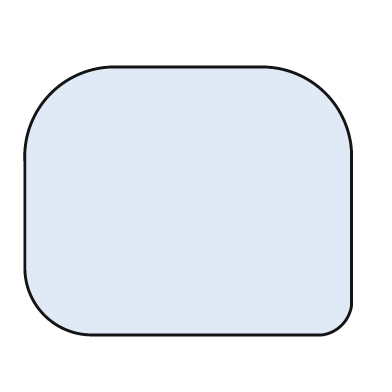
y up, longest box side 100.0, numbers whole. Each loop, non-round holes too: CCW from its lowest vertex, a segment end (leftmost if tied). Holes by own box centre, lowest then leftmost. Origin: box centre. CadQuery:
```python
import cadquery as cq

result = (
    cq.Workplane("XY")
    .moveTo(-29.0, -41.0)
    .lineTo(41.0, -41.0)
    .threePointArc((47.0, -38.0), (50.0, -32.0))
    .lineTo(50.0, 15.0)
    .threePointArc((42.0, 33.0), (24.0, 41.0))
    .lineTo(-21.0, 41.0)
    .threePointArc((-42.0, 33.0), (-50.0, 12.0))
    .lineTo(-50.0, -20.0)
    .threePointArc((-44.0, -35.0), (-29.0, -41.0))
    .close()
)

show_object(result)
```